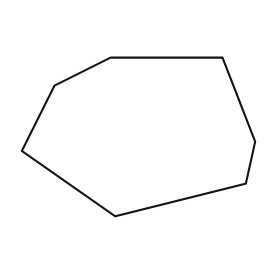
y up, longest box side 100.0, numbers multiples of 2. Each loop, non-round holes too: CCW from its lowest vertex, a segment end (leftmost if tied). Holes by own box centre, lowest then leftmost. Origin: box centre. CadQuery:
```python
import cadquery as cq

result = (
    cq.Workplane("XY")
    .moveTo(-10.0, -34.0)
    .lineTo(46.0, -20.0)
    .lineTo(50.0, -2.0)
    .lineTo(36.0, 34.0)
    .lineTo(-12.0, 34.0)
    .lineTo(-36.0, 22.0)
    .lineTo(-50.0, -6.0)
    .close()
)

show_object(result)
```